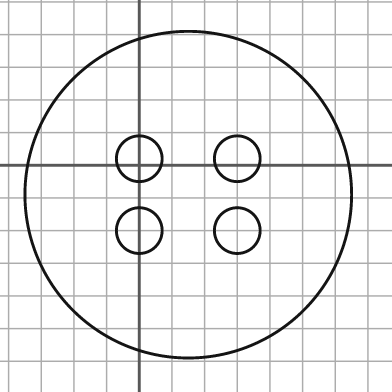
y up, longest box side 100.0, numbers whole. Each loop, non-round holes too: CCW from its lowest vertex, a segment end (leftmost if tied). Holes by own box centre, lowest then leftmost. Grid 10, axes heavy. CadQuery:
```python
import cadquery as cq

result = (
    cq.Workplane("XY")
    .moveTo(15.0, -9.0)
    .circle(50.0)
    .moveTo(0.0, -20.0)
    .circle(7.0)
    .moveTo(30.0, -20.0)
    .circle(7.0)
    .moveTo(0.0, 2.0)
    .circle(7.0)
    .moveTo(30.0, 2.0)
    .circle(7.0)
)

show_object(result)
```